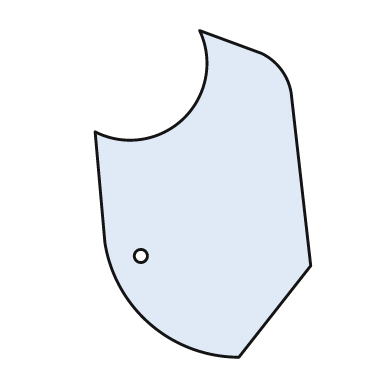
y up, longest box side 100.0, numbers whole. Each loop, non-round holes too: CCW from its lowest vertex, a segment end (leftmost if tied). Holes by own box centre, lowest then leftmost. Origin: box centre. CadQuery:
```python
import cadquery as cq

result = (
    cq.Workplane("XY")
    .moveTo(11.0, -50.0)
    .lineTo(33.0, -22.0)
    .lineTo(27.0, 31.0)
    .threePointArc((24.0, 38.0), (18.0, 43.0))
    .lineTo(-1.0, 50.0)
    .threePointArc((-6.0, 23.0), (-33.0, 19.0))
    .lineTo(-30.0, -15.0)
    .threePointArc((-16.0, -40.0), (11.0, -50.0))
    .close()
    .moveTo(-19.0, -19.0)
    .circle(2.0)
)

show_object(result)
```